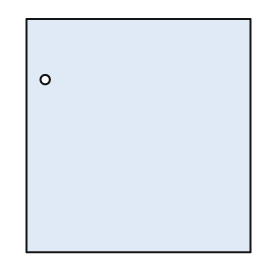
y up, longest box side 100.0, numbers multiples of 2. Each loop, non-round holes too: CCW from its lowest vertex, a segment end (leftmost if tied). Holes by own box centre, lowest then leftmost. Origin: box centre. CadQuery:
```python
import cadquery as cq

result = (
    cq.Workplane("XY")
    .moveTo(-48.0, -50.0)
    .lineTo(48.0, -50.0)
    .lineTo(48.0, 50.0)
    .lineTo(-48.0, 50.0)
    .close()
    .moveTo(-40.0, 24.0)
    .circle(2.0)
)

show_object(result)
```